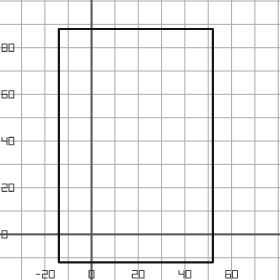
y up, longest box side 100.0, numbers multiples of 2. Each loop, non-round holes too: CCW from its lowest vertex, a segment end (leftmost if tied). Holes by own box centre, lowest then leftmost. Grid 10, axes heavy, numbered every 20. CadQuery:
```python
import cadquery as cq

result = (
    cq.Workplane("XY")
    .moveTo(-14.0, -12.0)
    .lineTo(52.0, -12.0)
    .lineTo(52.0, 88.0)
    .lineTo(-14.0, 88.0)
    .close()
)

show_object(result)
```